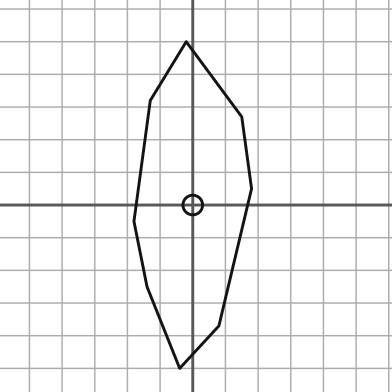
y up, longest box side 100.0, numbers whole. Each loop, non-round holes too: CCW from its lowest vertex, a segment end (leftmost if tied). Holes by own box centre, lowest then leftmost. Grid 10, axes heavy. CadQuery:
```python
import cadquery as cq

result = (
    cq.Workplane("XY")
    .moveTo(-4.0, -50.0)
    .lineTo(8.0, -37.0)
    .lineTo(18.0, 5.0)
    .lineTo(15.0, 27.0)
    .lineTo(-2.0, 50.0)
    .lineTo(-13.0, 32.0)
    .lineTo(-18.0, -5.0)
    .lineTo(-14.0, -25.0)
    .close()
    .moveTo(0.0, 0.0)
    .circle(3.0)
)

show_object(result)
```